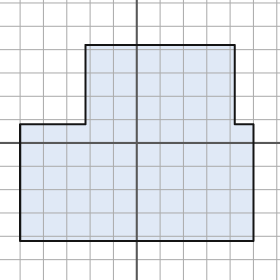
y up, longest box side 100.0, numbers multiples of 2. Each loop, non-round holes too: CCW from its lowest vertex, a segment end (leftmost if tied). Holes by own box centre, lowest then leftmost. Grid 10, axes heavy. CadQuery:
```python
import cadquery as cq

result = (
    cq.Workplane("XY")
    .moveTo(-50.0, -42.0)
    .lineTo(50.0, -42.0)
    .lineTo(50.0, 8.0)
    .lineTo(42.0, 8.0)
    .lineTo(42.0, 42.0)
    .lineTo(-22.0, 42.0)
    .lineTo(-22.0, 8.0)
    .lineTo(-50.0, 8.0)
    .close()
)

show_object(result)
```